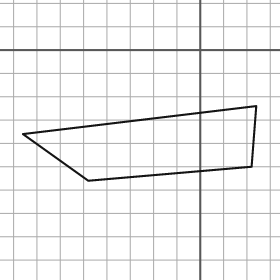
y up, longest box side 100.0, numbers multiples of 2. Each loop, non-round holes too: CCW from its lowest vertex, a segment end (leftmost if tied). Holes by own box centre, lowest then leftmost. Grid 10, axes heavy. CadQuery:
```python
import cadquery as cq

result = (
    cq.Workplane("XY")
    .moveTo(-48.0, -56.0)
    .lineTo(22.0, -50.0)
    .lineTo(24.0, -24.0)
    .lineTo(-76.0, -36.0)
    .close()
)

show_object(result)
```